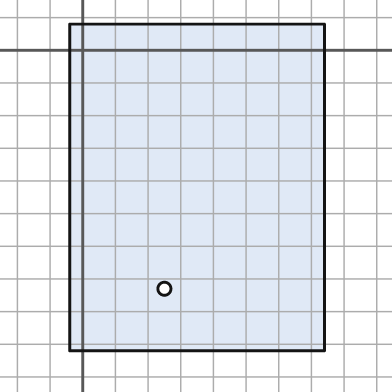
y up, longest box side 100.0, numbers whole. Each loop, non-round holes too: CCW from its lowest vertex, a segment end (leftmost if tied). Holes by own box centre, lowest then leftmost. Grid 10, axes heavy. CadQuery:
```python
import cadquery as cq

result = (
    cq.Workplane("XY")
    .moveTo(-4.0, -92.0)
    .lineTo(74.0, -92.0)
    .lineTo(74.0, 8.0)
    .lineTo(-4.0, 8.0)
    .close()
    .moveTo(25.0, -73.0)
    .circle(2.0)
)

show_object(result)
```